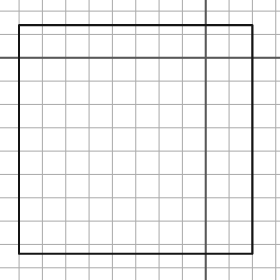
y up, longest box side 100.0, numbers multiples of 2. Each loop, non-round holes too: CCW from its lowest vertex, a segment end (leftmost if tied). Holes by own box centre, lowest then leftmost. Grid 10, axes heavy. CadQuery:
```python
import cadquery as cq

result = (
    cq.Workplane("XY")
    .moveTo(-80.0, -84.0)
    .lineTo(20.0, -84.0)
    .lineTo(20.0, 14.0)
    .lineTo(-80.0, 14.0)
    .close()
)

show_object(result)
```